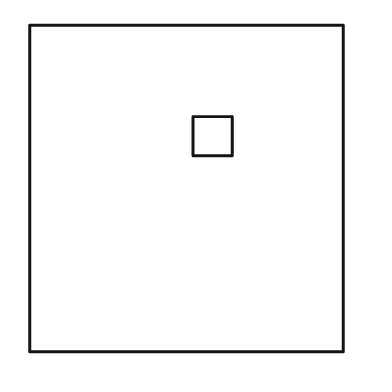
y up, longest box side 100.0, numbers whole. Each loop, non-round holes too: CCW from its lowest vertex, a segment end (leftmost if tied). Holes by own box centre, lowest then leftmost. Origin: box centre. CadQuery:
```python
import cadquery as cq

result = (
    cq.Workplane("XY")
    .moveTo(-48.0, -50.0)
    .lineTo(48.0, -50.0)
    .lineTo(48.0, 50.0)
    .lineTo(-48.0, 50.0)
    .close()
    .moveTo(2.0, 10.0)
    .lineTo(14.0, 10.0)
    .lineTo(14.0, 22.0)
    .lineTo(2.0, 22.0)
    .close()
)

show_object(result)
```